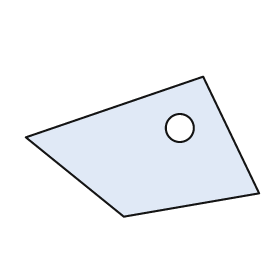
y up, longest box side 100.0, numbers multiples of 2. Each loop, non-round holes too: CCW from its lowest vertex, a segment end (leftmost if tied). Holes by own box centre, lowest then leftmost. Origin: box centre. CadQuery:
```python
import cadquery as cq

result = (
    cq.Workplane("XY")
    .moveTo(-8.0, -30.0)
    .lineTo(50.0, -20.0)
    .lineTo(26.0, 30.0)
    .lineTo(-50.0, 4.0)
    .close()
    .moveTo(16.0, 8.0)
    .circle(6.0)
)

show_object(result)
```